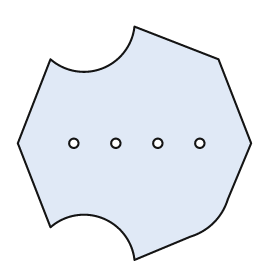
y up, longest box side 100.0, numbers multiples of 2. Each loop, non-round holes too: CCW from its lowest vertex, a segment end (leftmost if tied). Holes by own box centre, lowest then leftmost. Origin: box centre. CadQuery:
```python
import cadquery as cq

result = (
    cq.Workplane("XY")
    .moveTo(0.0, -50.0)
    .lineTo(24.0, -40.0)
    .threePointArc((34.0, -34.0), (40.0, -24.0))
    .lineTo(50.0, 0.0)
    .lineTo(36.0, 36.0)
    .lineTo(0.0, 50.0)
    .threePointArc((-14.0, 32.0), (-36.0, 36.0))
    .lineTo(-50.0, 0.0)
    .lineTo(-36.0, -36.0)
    .threePointArc((-14.0, -32.0), (0.0, -50.0))
    .close()
    .moveTo(-26.0, 0.0)
    .circle(2.0)
    .moveTo(-8.0, 0.0)
    .circle(2.0)
    .moveTo(10.0, 0.0)
    .circle(2.0)
    .moveTo(28.0, 0.0)
    .circle(2.0)
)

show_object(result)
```